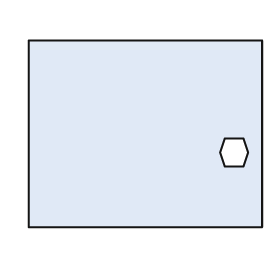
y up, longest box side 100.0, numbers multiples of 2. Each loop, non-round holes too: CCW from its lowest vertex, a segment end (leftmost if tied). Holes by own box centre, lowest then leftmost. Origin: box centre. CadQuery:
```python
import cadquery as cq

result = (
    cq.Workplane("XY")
    .moveTo(-50.0, -40.0)
    .lineTo(50.0, -40.0)
    .lineTo(50.0, 40.0)
    .lineTo(-50.0, 40.0)
    .close()
    .moveTo(34.0, -14.0)
    .lineTo(42.0, -14.0)
    .lineTo(44.0, -8.0)
    .lineTo(42.0, -2.0)
    .lineTo(34.0, -2.0)
    .lineTo(32.0, -8.0)
    .close()
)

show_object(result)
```